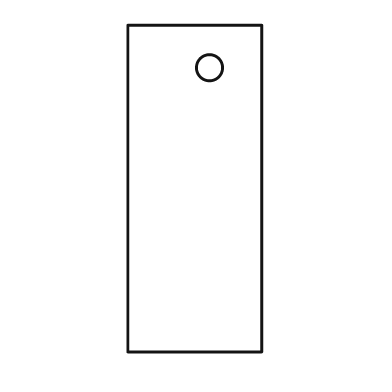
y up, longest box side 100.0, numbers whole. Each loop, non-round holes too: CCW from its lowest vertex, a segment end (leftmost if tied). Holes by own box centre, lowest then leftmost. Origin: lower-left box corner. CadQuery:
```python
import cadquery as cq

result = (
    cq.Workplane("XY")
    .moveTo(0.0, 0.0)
    .lineTo(41.0, 0.0)
    .lineTo(41.0, 100.0)
    .lineTo(0.0, 100.0)
    .close()
    .moveTo(25.0, 87.0)
    .circle(4.0)
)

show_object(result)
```